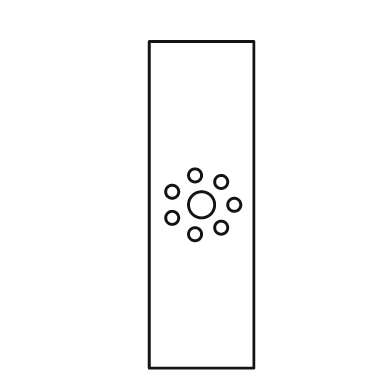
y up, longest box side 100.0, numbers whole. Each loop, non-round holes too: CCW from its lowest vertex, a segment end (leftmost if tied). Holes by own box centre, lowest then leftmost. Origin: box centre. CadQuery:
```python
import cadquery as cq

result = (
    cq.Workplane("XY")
    .moveTo(-16.0, -50.0)
    .lineTo(16.0, -50.0)
    .lineTo(16.0, 50.0)
    .lineTo(-16.0, 50.0)
    .close()
    .moveTo(-2.0, -9.0)
    .circle(2.0)
    .moveTo(6.0, -7.0)
    .circle(2.0)
    .moveTo(-9.0, -4.0)
    .circle(2.0)
    .moveTo(0.0, 0.0)
    .circle(4.0)
    .moveTo(10.0, 0.0)
    .circle(2.0)
    .moveTo(-9.0, 4.0)
    .circle(2.0)
    .moveTo(6.0, 7.0)
    .circle(2.0)
    .moveTo(-2.0, 9.0)
    .circle(2.0)
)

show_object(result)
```